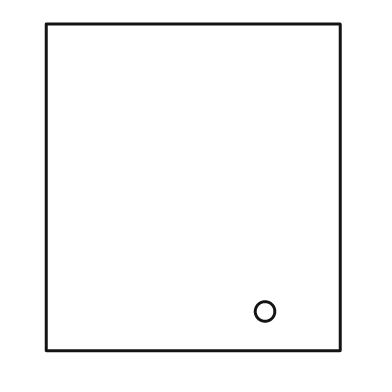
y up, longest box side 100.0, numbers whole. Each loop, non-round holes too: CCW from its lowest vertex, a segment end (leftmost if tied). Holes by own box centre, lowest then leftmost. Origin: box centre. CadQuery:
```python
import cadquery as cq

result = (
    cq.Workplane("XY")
    .moveTo(-45.0, -50.0)
    .lineTo(45.0, -50.0)
    .lineTo(45.0, 50.0)
    .lineTo(-45.0, 50.0)
    .close()
    .moveTo(22.0, -38.0)
    .circle(3.0)
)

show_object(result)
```